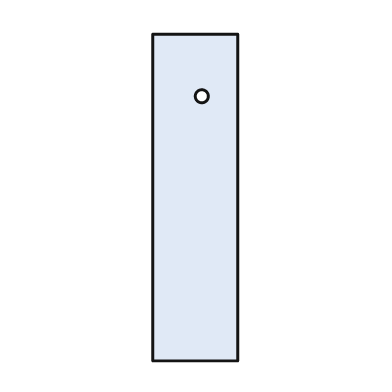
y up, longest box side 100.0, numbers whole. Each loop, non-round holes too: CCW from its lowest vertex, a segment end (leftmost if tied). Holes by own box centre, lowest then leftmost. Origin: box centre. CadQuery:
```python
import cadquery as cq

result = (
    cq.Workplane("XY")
    .moveTo(-13.0, -50.0)
    .lineTo(13.0, -50.0)
    .lineTo(13.0, 50.0)
    .lineTo(-13.0, 50.0)
    .close()
    .moveTo(2.0, 31.0)
    .circle(2.0)
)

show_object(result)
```